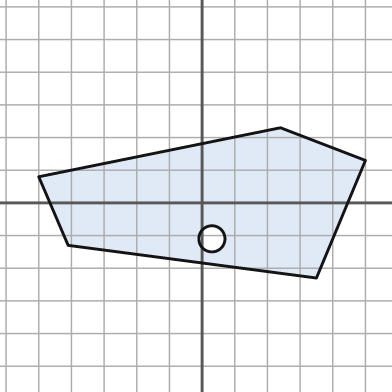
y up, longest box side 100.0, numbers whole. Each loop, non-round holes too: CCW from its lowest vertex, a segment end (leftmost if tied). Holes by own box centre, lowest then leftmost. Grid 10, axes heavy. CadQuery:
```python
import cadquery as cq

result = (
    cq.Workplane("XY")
    .moveTo(35.0, -23.0)
    .lineTo(50.0, 13.0)
    .lineTo(24.0, 23.0)
    .lineTo(-50.0, 8.0)
    .lineTo(-41.0, -13.0)
    .close()
    .moveTo(3.0, -11.0)
    .circle(4.0)
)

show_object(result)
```